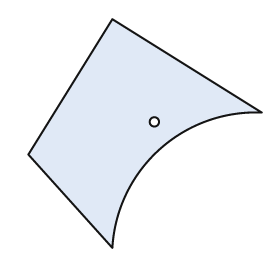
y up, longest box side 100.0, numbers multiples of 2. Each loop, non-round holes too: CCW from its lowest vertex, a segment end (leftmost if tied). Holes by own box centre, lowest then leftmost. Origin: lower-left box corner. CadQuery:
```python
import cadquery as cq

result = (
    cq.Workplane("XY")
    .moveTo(36.0, 0.0)
    .threePointArc((56.0, 42.0), (100.0, 58.0))
    .lineTo(36.0, 98.0)
    .lineTo(0.0, 40.0)
    .close()
    .moveTo(54.0, 54.0)
    .circle(2.0)
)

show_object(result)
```